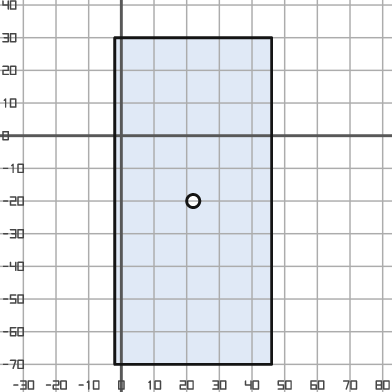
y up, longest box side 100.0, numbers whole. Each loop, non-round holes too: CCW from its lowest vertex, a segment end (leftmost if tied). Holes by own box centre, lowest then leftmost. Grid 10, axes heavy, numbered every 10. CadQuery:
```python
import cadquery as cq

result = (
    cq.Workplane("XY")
    .moveTo(-2.0, -70.0)
    .lineTo(46.0, -70.0)
    .lineTo(46.0, 30.0)
    .lineTo(-2.0, 30.0)
    .close()
    .moveTo(22.0, -20.0)
    .circle(2.0)
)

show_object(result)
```